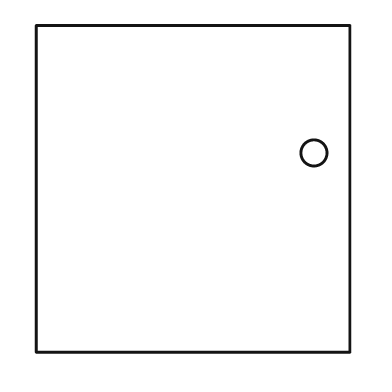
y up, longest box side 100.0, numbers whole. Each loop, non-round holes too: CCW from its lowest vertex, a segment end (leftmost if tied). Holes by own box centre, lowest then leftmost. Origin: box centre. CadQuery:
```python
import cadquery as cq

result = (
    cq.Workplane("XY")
    .moveTo(-48.0, -50.0)
    .lineTo(48.0, -50.0)
    .lineTo(48.0, 50.0)
    .lineTo(-48.0, 50.0)
    .close()
    .moveTo(37.0, 11.0)
    .circle(4.0)
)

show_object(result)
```